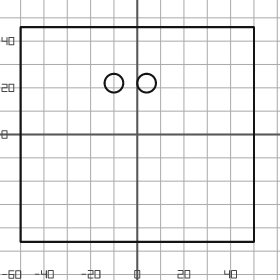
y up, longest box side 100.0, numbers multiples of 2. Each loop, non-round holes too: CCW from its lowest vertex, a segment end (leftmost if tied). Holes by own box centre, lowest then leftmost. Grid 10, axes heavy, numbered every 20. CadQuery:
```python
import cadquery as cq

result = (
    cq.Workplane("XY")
    .moveTo(-50.0, -46.0)
    .lineTo(50.0, -46.0)
    .lineTo(50.0, 46.0)
    .lineTo(-50.0, 46.0)
    .close()
    .moveTo(-10.0, 22.0)
    .circle(4.0)
    .moveTo(4.0, 22.0)
    .circle(4.0)
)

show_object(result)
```